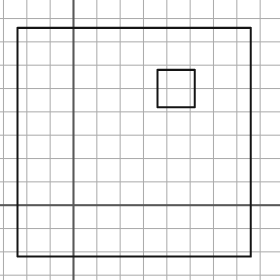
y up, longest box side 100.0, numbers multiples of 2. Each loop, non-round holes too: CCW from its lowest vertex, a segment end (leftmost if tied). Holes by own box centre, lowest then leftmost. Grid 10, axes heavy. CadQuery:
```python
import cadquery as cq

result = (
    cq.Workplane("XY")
    .moveTo(-24.0, -22.0)
    .lineTo(76.0, -22.0)
    .lineTo(76.0, 76.0)
    .lineTo(-24.0, 76.0)
    .close()
    .moveTo(36.0, 42.0)
    .lineTo(52.0, 42.0)
    .lineTo(52.0, 58.0)
    .lineTo(36.0, 58.0)
    .close()
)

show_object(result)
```